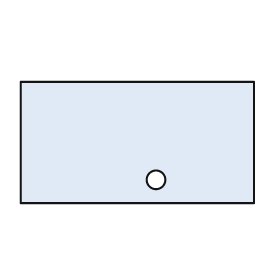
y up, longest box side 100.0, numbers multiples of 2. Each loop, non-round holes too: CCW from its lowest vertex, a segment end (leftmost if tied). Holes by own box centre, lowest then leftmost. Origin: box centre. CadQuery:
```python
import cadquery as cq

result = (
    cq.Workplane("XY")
    .moveTo(-50.0, -26.0)
    .lineTo(50.0, -26.0)
    .lineTo(50.0, 26.0)
    .lineTo(-50.0, 26.0)
    .close()
    .moveTo(8.0, -16.0)
    .circle(4.0)
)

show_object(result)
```